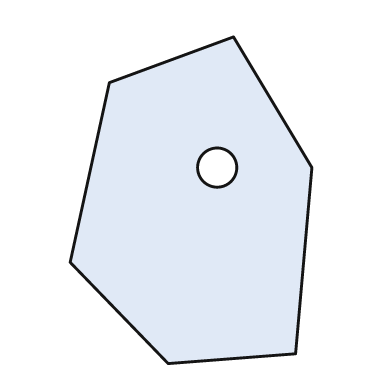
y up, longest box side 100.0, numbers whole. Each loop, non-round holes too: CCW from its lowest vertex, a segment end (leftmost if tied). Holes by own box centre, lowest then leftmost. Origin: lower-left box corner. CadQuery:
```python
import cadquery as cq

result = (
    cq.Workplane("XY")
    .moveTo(30.0, 0.0)
    .lineTo(69.0, 3.0)
    .lineTo(74.0, 60.0)
    .lineTo(50.0, 100.0)
    .lineTo(12.0, 86.0)
    .lineTo(0.0, 31.0)
    .close()
    .moveTo(45.0, 60.0)
    .circle(6.0)
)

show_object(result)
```